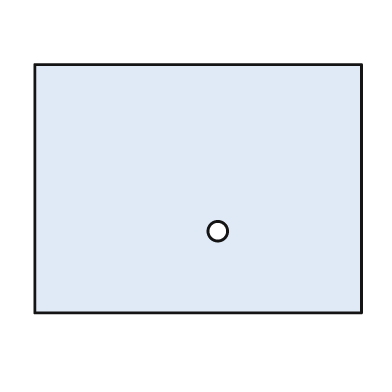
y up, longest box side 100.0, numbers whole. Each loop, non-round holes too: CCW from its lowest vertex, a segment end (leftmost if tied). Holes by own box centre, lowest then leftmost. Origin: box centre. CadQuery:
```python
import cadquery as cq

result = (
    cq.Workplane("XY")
    .moveTo(-50.0, -38.0)
    .lineTo(50.0, -38.0)
    .lineTo(50.0, 38.0)
    .lineTo(-50.0, 38.0)
    .close()
    .moveTo(6.0, -13.0)
    .circle(3.0)
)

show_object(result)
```